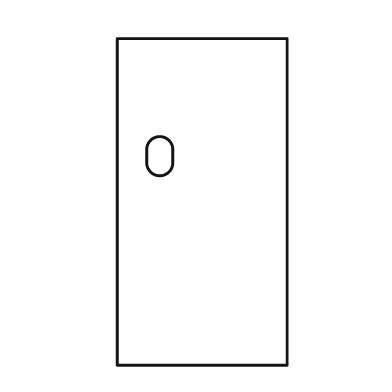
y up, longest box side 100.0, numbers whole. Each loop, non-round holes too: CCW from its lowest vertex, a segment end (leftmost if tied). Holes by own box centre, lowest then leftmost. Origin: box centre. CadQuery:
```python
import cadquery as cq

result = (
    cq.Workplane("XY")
    .moveTo(-26.0, -50.0)
    .lineTo(26.0, -50.0)
    .lineTo(26.0, 50.0)
    .lineTo(-26.0, 50.0)
    .close()
    .moveTo(-17.0, 12.0)
    .threePointArc((-13.0, 8.0), (-9.0, 12.0))
    .lineTo(-9.0, 16.0)
    .threePointArc((-13.0, 20.0), (-17.0, 16.0))
    .close()
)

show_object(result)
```